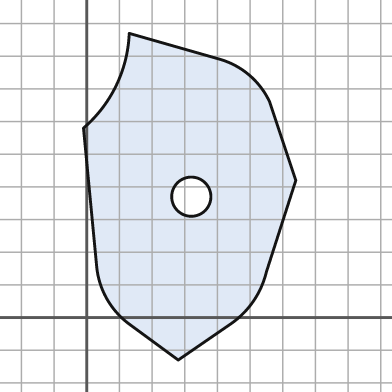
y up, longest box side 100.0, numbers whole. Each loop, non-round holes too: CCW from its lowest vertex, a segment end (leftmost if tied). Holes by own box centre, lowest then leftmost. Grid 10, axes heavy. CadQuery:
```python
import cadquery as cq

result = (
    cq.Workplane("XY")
    .moveTo(28.0, -13.0)
    .lineTo(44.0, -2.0)
    .threePointArc((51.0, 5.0), (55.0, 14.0))
    .lineTo(64.0, 42.0)
    .lineTo(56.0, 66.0)
    .threePointArc((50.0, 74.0), (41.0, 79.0))
    .lineTo(13.0, 87.0)
    .threePointArc((9.0, 71.0), (-1.0, 58.0))
    .lineTo(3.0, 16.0)
    .threePointArc((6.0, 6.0), (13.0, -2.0))
    .close()
    .moveTo(32.0, 37.0)
    .circle(6.0)
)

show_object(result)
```